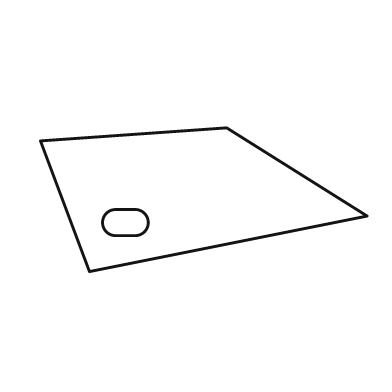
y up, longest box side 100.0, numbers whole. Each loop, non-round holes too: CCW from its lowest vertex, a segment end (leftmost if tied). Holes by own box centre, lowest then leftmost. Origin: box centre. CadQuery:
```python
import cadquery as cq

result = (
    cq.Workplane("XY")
    .moveTo(-35.0, -22.0)
    .lineTo(50.0, -5.0)
    .lineTo(7.0, 22.0)
    .lineTo(-50.0, 18.0)
    .close()
    .moveTo(-27.0, -11.0)
    .lineTo(-21.0, -11.0)
    .threePointArc((-17.0, -7.0), (-21.0, -3.0))
    .lineTo(-27.0, -3.0)
    .threePointArc((-31.0, -7.0), (-27.0, -11.0))
    .close()
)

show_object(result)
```